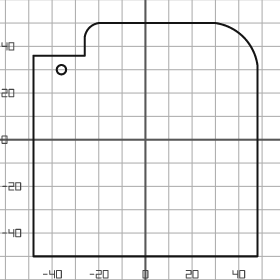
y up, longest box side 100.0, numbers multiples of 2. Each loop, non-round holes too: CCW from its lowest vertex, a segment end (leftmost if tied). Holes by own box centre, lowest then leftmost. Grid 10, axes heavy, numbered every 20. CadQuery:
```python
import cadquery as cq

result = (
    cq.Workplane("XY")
    .moveTo(-48.0, -50.0)
    .lineTo(48.0, -50.0)
    .lineTo(48.0, 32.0)
    .threePointArc((42.0, 44.0), (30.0, 50.0))
    .lineTo(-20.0, 50.0)
    .threePointArc((-24.0, 48.0), (-26.0, 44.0))
    .lineTo(-26.0, 36.0)
    .lineTo(-48.0, 36.0)
    .close()
    .moveTo(-36.0, 30.0)
    .circle(2.0)
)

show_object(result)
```